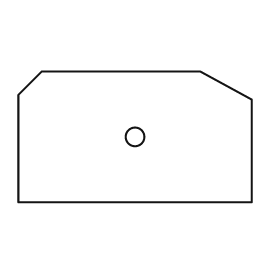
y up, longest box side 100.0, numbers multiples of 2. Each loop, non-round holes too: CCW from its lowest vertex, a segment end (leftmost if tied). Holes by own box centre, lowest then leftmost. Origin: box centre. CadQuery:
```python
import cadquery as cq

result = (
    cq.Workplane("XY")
    .moveTo(-50.0, -28.0)
    .lineTo(50.0, -28.0)
    .lineTo(50.0, 16.0)
    .lineTo(28.0, 28.0)
    .lineTo(-40.0, 28.0)
    .lineTo(-50.0, 18.0)
    .close()
    .moveTo(0.0, 0.0)
    .circle(4.0)
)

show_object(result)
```